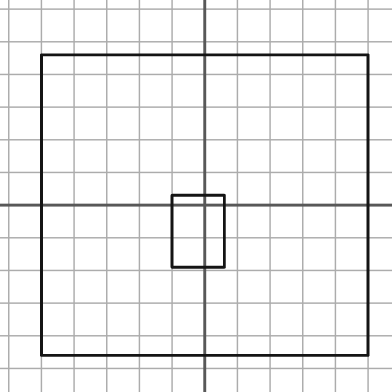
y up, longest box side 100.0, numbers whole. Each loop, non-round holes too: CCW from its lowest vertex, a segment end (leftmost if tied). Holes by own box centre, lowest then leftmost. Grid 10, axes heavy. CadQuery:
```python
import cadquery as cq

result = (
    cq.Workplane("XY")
    .moveTo(-50.0, -46.0)
    .lineTo(50.0, -46.0)
    .lineTo(50.0, 46.0)
    .lineTo(-50.0, 46.0)
    .close()
    .moveTo(-10.0, -19.0)
    .lineTo(6.0, -19.0)
    .lineTo(6.0, 3.0)
    .lineTo(-10.0, 3.0)
    .close()
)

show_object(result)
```